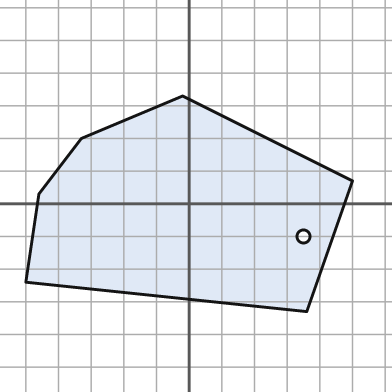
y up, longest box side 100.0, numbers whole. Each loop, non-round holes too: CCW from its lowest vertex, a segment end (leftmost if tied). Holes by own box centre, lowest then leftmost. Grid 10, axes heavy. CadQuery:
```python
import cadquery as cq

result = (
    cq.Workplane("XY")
    .moveTo(36.0, -33.0)
    .lineTo(50.0, 7.0)
    .lineTo(-2.0, 33.0)
    .lineTo(-33.0, 20.0)
    .lineTo(-46.0, 3.0)
    .lineTo(-50.0, -24.0)
    .close()
    .moveTo(35.0, -10.0)
    .circle(2.0)
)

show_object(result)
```